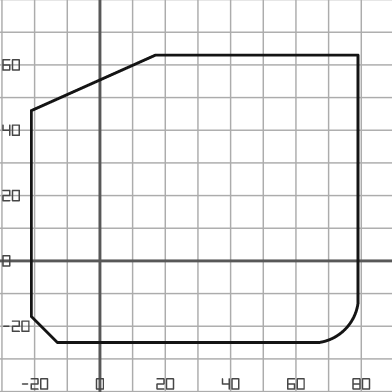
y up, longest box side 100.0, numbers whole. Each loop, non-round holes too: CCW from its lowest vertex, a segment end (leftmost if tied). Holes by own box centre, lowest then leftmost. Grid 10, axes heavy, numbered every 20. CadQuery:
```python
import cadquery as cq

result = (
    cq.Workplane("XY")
    .moveTo(-13.0, -25.0)
    .lineTo(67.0, -25.0)
    .threePointArc((75.0, -21.0), (79.0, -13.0))
    .lineTo(79.0, 63.0)
    .lineTo(17.0, 63.0)
    .lineTo(-21.0, 46.0)
    .lineTo(-21.0, -17.0)
    .close()
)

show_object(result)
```